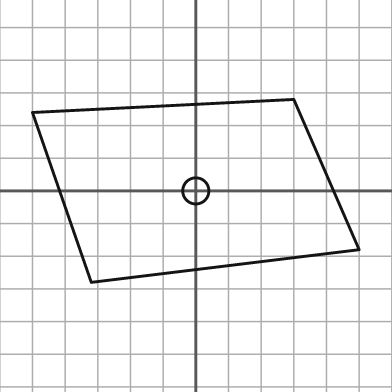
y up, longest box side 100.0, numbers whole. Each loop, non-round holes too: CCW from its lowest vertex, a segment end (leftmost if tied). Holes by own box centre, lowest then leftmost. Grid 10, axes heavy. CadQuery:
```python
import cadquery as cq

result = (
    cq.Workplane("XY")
    .moveTo(-32.0, -28.0)
    .lineTo(50.0, -18.0)
    .lineTo(30.0, 28.0)
    .lineTo(-50.0, 24.0)
    .close()
    .moveTo(0.0, 0.0)
    .circle(4.0)
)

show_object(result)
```